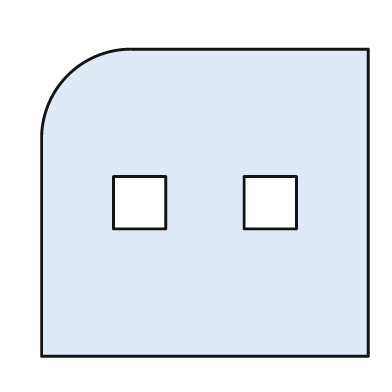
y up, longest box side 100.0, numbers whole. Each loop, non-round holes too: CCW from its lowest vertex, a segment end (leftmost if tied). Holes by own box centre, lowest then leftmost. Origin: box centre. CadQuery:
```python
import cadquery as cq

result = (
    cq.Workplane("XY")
    .moveTo(-50.0, -47.0)
    .lineTo(50.0, -47.0)
    .lineTo(50.0, 47.0)
    .lineTo(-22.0, 47.0)
    .threePointArc((-42.0, 39.0), (-50.0, 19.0))
    .close()
    .moveTo(-28.0, -8.0)
    .lineTo(-12.0, -8.0)
    .lineTo(-12.0, 8.0)
    .lineTo(-28.0, 8.0)
    .close()
    .moveTo(12.0, -8.0)
    .lineTo(28.0, -8.0)
    .lineTo(28.0, 8.0)
    .lineTo(12.0, 8.0)
    .close()
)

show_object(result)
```